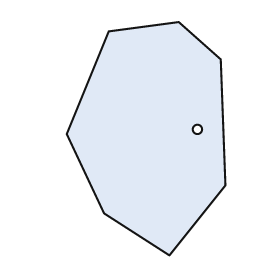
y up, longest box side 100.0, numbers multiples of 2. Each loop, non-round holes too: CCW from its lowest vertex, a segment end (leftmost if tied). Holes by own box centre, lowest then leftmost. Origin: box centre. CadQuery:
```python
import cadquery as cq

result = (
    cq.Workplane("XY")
    .moveTo(10.0, -50.0)
    .lineTo(34.0, -20.0)
    .lineTo(32.0, 34.0)
    .lineTo(14.0, 50.0)
    .lineTo(-16.0, 46.0)
    .lineTo(-34.0, 2.0)
    .lineTo(-18.0, -32.0)
    .close()
    .moveTo(22.0, 4.0)
    .circle(2.0)
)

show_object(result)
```